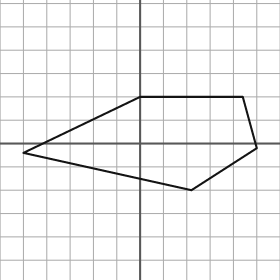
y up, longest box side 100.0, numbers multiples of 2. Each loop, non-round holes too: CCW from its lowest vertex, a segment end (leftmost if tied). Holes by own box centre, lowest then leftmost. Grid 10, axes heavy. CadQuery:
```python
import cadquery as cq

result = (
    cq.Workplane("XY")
    .moveTo(22.0, -20.0)
    .lineTo(50.0, -2.0)
    .lineTo(44.0, 20.0)
    .lineTo(0.0, 20.0)
    .lineTo(-50.0, -4.0)
    .close()
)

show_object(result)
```